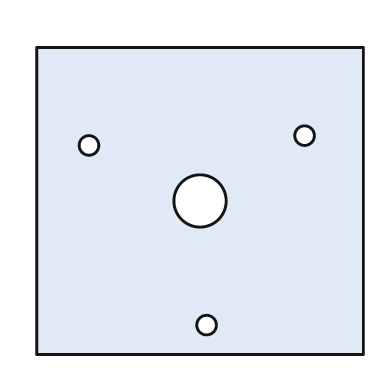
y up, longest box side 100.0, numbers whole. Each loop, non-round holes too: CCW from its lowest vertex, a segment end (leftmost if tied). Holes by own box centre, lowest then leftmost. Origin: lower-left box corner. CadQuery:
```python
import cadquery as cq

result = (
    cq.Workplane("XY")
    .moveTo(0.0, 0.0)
    .lineTo(100.0, 0.0)
    .lineTo(100.0, 94.0)
    .lineTo(0.0, 94.0)
    .close()
    .moveTo(52.0, 9.0)
    .circle(3.0)
    .moveTo(50.0, 47.0)
    .circle(8.0)
    .moveTo(16.0, 64.0)
    .circle(3.0)
    .moveTo(82.0, 67.0)
    .circle(3.0)
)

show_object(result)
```